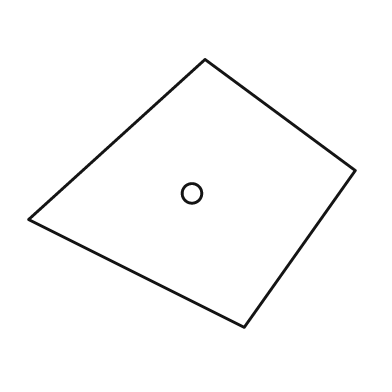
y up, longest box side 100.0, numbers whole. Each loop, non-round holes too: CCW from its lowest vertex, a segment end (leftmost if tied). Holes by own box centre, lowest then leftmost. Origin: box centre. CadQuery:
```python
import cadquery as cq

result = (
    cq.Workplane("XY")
    .moveTo(16.0, -41.0)
    .lineTo(50.0, 7.0)
    .lineTo(4.0, 41.0)
    .lineTo(-50.0, -8.0)
    .close()
    .moveTo(0.0, 0.0)
    .circle(3.0)
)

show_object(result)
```